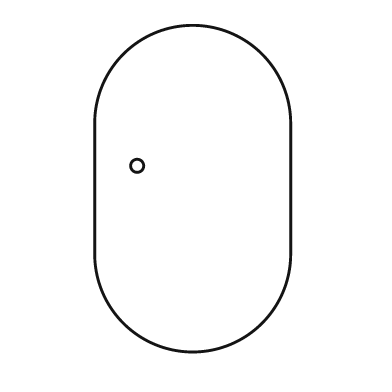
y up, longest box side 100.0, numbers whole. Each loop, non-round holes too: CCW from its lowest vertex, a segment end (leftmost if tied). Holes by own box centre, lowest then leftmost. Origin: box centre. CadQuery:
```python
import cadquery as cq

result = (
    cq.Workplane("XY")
    .moveTo(-30.0, -20.0)
    .threePointArc((0.0, -50.0), (30.0, -20.0))
    .lineTo(30.0, 20.0)
    .threePointArc((0.0, 50.0), (-30.0, 20.0))
    .close()
    .moveTo(-17.0, 7.0)
    .circle(2.0)
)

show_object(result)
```